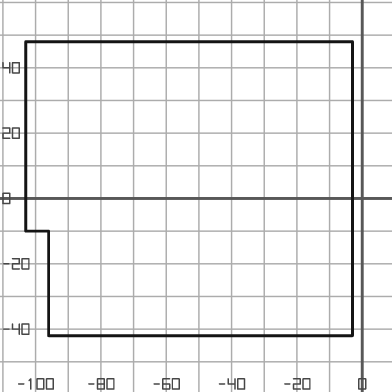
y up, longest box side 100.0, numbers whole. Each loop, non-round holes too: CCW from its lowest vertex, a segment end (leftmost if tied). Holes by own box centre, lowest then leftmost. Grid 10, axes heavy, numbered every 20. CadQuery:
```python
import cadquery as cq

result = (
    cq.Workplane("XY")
    .moveTo(-96.0, -42.0)
    .lineTo(-3.0, -42.0)
    .lineTo(-3.0, 48.0)
    .lineTo(-103.0, 48.0)
    .lineTo(-103.0, -10.0)
    .lineTo(-96.0, -10.0)
    .close()
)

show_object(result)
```